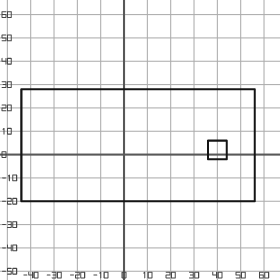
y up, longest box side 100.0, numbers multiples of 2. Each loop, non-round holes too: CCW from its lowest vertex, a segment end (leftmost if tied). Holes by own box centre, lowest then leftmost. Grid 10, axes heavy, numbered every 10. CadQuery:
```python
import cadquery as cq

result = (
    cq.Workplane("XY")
    .moveTo(-44.0, -20.0)
    .lineTo(56.0, -20.0)
    .lineTo(56.0, 28.0)
    .lineTo(-44.0, 28.0)
    .close()
    .moveTo(36.0, -2.0)
    .lineTo(44.0, -2.0)
    .lineTo(44.0, 6.0)
    .lineTo(36.0, 6.0)
    .close()
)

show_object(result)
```